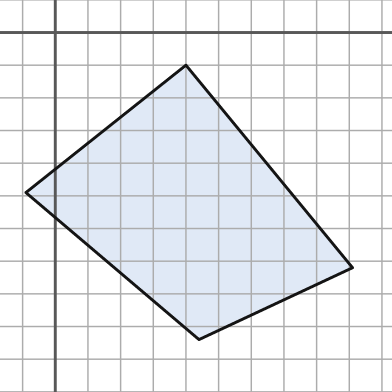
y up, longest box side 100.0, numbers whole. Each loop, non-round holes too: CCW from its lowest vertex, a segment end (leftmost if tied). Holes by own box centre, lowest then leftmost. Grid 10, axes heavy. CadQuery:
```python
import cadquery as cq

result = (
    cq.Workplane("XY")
    .moveTo(44.0, -94.0)
    .lineTo(91.0, -72.0)
    .lineTo(40.0, -10.0)
    .lineTo(-9.0, -49.0)
    .close()
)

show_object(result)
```